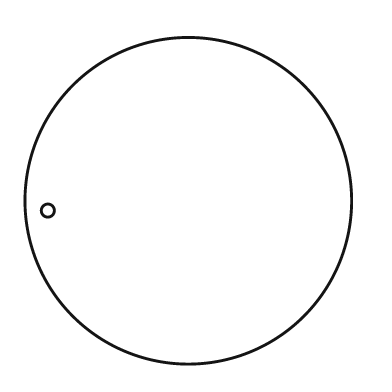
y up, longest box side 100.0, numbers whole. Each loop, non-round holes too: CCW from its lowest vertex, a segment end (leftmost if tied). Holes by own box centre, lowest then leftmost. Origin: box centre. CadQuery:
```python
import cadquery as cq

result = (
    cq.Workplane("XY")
    .moveTo(0.0, 0.0)
    .circle(50.0)
    .moveTo(-43.0, -3.0)
    .circle(2.0)
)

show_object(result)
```